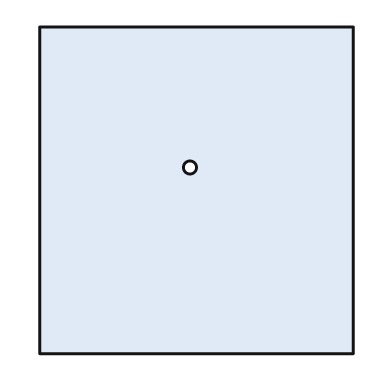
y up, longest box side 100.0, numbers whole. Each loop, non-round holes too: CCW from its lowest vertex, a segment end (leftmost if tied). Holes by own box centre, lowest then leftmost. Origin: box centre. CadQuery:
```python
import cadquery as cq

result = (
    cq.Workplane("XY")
    .moveTo(-48.0, -50.0)
    .lineTo(48.0, -50.0)
    .lineTo(48.0, 50.0)
    .lineTo(-48.0, 50.0)
    .close()
    .moveTo(-2.0, 7.0)
    .circle(2.0)
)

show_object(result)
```